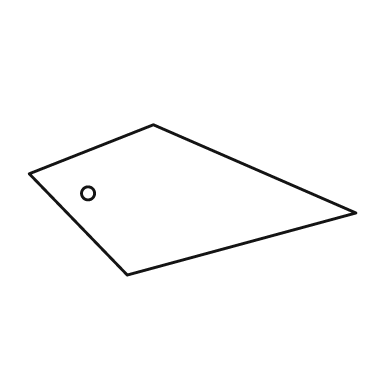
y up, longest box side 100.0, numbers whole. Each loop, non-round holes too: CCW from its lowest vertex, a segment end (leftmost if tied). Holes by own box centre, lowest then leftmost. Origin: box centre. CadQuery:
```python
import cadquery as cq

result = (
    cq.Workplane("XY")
    .moveTo(-20.0, -23.0)
    .lineTo(50.0, -4.0)
    .lineTo(-12.0, 23.0)
    .lineTo(-50.0, 8.0)
    .close()
    .moveTo(-32.0, 2.0)
    .circle(2.0)
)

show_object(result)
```